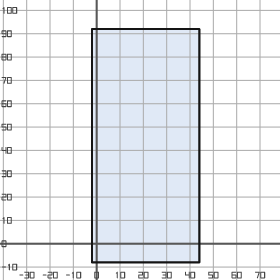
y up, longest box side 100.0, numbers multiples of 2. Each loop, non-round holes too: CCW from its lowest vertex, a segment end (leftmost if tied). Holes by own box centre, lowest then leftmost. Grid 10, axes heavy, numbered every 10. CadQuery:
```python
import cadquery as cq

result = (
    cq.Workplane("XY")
    .moveTo(-2.0, -8.0)
    .lineTo(44.0, -8.0)
    .lineTo(44.0, 92.0)
    .lineTo(-2.0, 92.0)
    .close()
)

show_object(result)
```